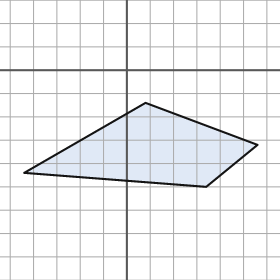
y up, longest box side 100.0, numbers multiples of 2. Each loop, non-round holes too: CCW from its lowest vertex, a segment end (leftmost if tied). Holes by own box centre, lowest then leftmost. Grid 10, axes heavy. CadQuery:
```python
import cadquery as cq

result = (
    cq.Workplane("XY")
    .moveTo(34.0, -50.0)
    .lineTo(56.0, -32.0)
    .lineTo(8.0, -14.0)
    .lineTo(-44.0, -44.0)
    .close()
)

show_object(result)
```